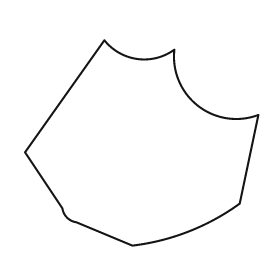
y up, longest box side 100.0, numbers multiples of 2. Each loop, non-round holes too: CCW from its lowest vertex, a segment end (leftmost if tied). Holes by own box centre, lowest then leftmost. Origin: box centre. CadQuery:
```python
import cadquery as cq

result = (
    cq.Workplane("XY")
    .moveTo(-4.0, -44.0)
    .threePointArc((20.0, -38.0), (42.0, -26.0))
    .lineTo(50.0, 12.0)
    .threePointArc((24.0, 16.0), (14.0, 40.0))
    .threePointArc((-2.0, 36.0), (-16.0, 44.0))
    .lineTo(-50.0, -4.0)
    .lineTo(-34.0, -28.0)
    .threePointArc((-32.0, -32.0), (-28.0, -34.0))
    .close()
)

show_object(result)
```